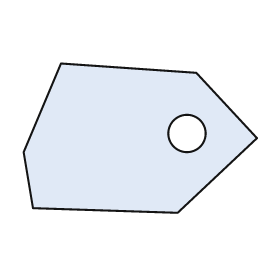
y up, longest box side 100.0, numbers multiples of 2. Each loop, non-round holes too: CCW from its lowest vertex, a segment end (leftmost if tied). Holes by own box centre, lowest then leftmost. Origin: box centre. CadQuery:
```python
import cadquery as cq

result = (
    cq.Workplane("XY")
    .moveTo(16.0, -32.0)
    .lineTo(50.0, 0.0)
    .lineTo(24.0, 28.0)
    .lineTo(-34.0, 32.0)
    .lineTo(-50.0, -6.0)
    .lineTo(-46.0, -30.0)
    .close()
    .moveTo(20.0, 2.0)
    .circle(8.0)
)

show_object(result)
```